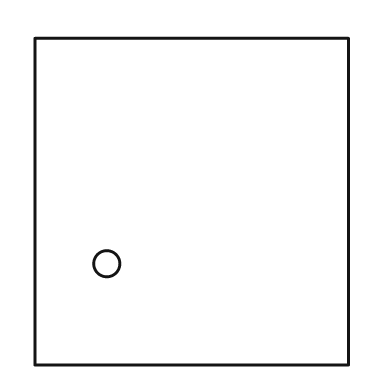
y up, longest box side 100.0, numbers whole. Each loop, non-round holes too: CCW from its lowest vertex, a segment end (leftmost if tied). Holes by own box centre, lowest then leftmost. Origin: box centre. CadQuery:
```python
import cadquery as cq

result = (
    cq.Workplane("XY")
    .moveTo(-48.0, -50.0)
    .lineTo(48.0, -50.0)
    .lineTo(48.0, 50.0)
    .lineTo(-48.0, 50.0)
    .close()
    .moveTo(-26.0, -19.0)
    .circle(4.0)
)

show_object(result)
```